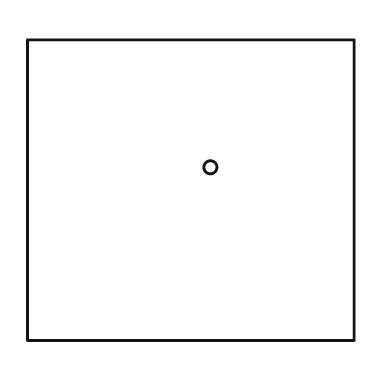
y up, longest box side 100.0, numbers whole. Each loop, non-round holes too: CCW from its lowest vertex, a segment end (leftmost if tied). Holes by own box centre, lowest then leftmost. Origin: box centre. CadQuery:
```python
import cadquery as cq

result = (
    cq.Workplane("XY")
    .moveTo(-50.0, -46.0)
    .lineTo(50.0, -46.0)
    .lineTo(50.0, 46.0)
    .lineTo(-50.0, 46.0)
    .close()
    .moveTo(6.0, 7.0)
    .circle(2.0)
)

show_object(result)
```